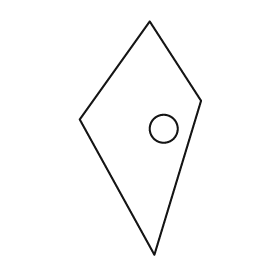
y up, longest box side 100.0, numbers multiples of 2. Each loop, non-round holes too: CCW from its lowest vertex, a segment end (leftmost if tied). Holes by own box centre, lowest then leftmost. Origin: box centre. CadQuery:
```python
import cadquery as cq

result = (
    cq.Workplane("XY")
    .moveTo(6.0, -50.0)
    .lineTo(26.0, 16.0)
    .lineTo(4.0, 50.0)
    .lineTo(-26.0, 8.0)
    .close()
    .moveTo(10.0, 4.0)
    .circle(6.0)
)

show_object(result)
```